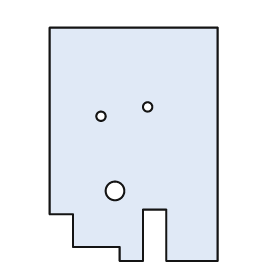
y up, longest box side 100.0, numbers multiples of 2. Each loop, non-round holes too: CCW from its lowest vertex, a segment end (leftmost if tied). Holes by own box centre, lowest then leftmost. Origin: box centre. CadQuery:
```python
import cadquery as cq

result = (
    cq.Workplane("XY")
    .moveTo(-6.0, -50.0)
    .lineTo(4.0, -50.0)
    .lineTo(4.0, -28.0)
    .lineTo(14.0, -28.0)
    .lineTo(14.0, -50.0)
    .lineTo(36.0, -50.0)
    .lineTo(36.0, 50.0)
    .lineTo(-36.0, 50.0)
    .lineTo(-36.0, -30.0)
    .lineTo(-26.0, -30.0)
    .lineTo(-26.0, -44.0)
    .lineTo(-6.0, -44.0)
    .close()
    .moveTo(-8.0, -20.0)
    .circle(4.0)
    .moveTo(-14.0, 12.0)
    .circle(2.0)
    .moveTo(6.0, 16.0)
    .circle(2.0)
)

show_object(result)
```